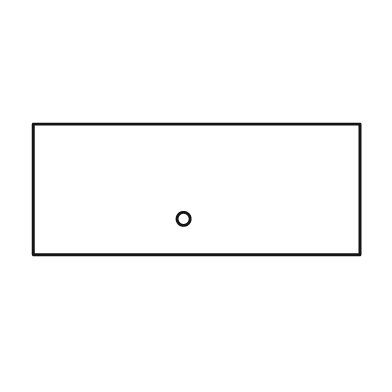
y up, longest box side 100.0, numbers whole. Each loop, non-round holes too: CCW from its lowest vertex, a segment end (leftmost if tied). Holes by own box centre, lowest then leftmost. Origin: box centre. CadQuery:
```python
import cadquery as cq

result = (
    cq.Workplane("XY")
    .moveTo(-50.0, -20.0)
    .lineTo(50.0, -20.0)
    .lineTo(50.0, 20.0)
    .lineTo(-50.0, 20.0)
    .close()
    .moveTo(-4.0, -9.0)
    .circle(2.0)
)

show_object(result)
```